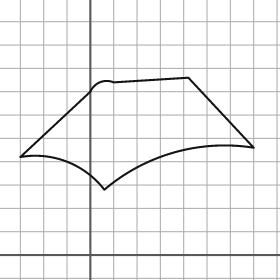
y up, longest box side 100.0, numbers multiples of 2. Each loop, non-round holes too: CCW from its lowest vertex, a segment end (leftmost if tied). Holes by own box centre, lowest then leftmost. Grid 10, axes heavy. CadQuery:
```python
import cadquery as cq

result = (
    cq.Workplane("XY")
    .moveTo(6.0, 28.0)
    .threePointArc((36.0, 44.0), (70.0, 46.0))
    .lineTo(42.0, 76.0)
    .lineTo(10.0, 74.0)
    .threePointArc((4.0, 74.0), (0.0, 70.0))
    .lineTo(-30.0, 42.0)
    .threePointArc((-10.0, 40.0), (6.0, 28.0))
    .close()
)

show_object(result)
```